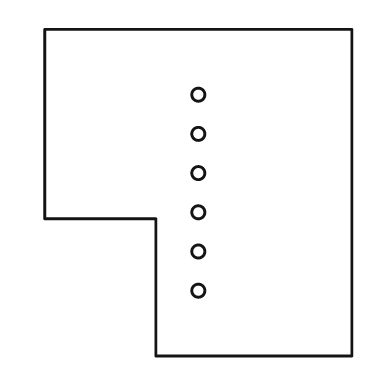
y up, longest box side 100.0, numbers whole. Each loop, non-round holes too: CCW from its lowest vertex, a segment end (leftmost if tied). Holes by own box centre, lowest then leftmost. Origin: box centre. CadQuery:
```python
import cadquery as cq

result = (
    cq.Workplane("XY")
    .moveTo(-13.0, -50.0)
    .lineTo(47.0, -50.0)
    .lineTo(47.0, 50.0)
    .lineTo(-47.0, 50.0)
    .lineTo(-47.0, -8.0)
    .lineTo(-13.0, -8.0)
    .close()
    .moveTo(0.0, -30.0)
    .circle(2.0)
    .moveTo(0.0, -18.0)
    .circle(2.0)
    .moveTo(0.0, -6.0)
    .circle(2.0)
    .moveTo(0.0, 6.0)
    .circle(2.0)
    .moveTo(0.0, 18.0)
    .circle(2.0)
    .moveTo(0.0, 30.0)
    .circle(2.0)
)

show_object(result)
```